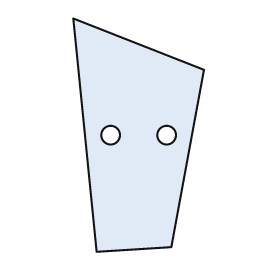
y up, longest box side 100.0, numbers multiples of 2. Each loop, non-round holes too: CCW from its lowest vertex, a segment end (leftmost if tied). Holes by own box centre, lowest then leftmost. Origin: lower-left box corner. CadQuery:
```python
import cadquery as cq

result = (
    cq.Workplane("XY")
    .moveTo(10.0, 0.0)
    .lineTo(42.0, 2.0)
    .lineTo(56.0, 78.0)
    .lineTo(0.0, 100.0)
    .close()
    .moveTo(16.0, 50.0)
    .circle(4.0)
    .moveTo(40.0, 50.0)
    .circle(4.0)
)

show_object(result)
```